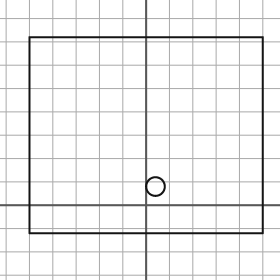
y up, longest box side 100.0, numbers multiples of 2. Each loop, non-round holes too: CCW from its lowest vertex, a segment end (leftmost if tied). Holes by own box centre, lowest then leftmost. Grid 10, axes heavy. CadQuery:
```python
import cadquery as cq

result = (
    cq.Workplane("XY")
    .moveTo(-50.0, -12.0)
    .lineTo(50.0, -12.0)
    .lineTo(50.0, 72.0)
    .lineTo(-50.0, 72.0)
    .close()
    .moveTo(4.0, 8.0)
    .circle(4.0)
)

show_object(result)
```